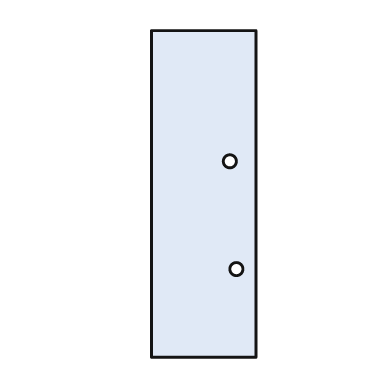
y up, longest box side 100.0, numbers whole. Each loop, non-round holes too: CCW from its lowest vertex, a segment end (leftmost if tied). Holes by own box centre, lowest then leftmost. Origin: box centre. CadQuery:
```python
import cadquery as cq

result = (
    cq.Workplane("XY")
    .moveTo(-16.0, -50.0)
    .lineTo(16.0, -50.0)
    .lineTo(16.0, 50.0)
    .lineTo(-16.0, 50.0)
    .close()
    .moveTo(10.0, -23.0)
    .circle(2.0)
    .moveTo(8.0, 10.0)
    .circle(2.0)
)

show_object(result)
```